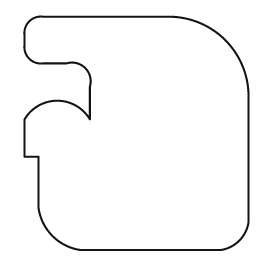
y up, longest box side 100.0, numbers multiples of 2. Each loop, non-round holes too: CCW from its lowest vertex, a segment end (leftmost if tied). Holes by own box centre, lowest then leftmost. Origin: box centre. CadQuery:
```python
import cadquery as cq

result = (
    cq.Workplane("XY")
    .moveTo(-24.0, -50.0)
    .lineTo(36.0, -50.0)
    .threePointArc((44.0, -46.0), (48.0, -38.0))
    .lineTo(48.0, 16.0)
    .threePointArc((38.0, 40.0), (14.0, 50.0))
    .lineTo(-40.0, 50.0)
    .threePointArc((-46.0, 48.0), (-48.0, 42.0))
    .lineTo(-48.0, 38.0)
    .threePointArc((-46.0, 32.0), (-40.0, 30.0))
    .lineTo(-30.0, 30.0)
    .threePointArc((-22.0, 28.0), (-20.0, 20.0))
    .lineTo(-20.0, 6.0)
    .threePointArc((-34.0, 14.0), (-48.0, 6.0))
    .lineTo(-48.0, -10.0)
    .lineTo(-42.0, -10.0)
    .lineTo(-42.0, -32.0)
    .threePointArc((-36.0, -44.0), (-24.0, -50.0))
    .close()
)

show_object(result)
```